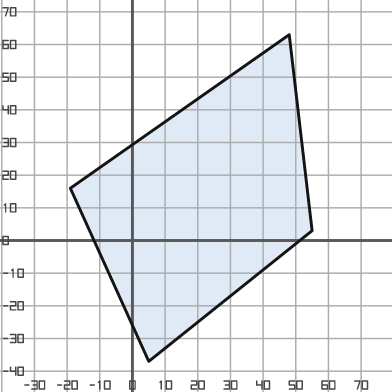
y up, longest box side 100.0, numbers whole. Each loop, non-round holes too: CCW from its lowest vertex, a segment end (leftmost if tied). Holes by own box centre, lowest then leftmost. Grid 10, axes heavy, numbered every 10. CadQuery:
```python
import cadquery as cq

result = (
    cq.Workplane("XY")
    .moveTo(5.0, -37.0)
    .lineTo(55.0, 3.0)
    .lineTo(48.0, 63.0)
    .lineTo(-19.0, 16.0)
    .close()
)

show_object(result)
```